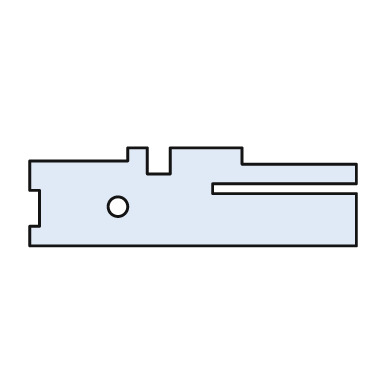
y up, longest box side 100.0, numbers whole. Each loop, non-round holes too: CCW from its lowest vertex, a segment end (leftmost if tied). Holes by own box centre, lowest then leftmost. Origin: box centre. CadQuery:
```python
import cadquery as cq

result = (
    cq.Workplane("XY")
    .moveTo(-50.0, -15.0)
    .lineTo(50.0, -15.0)
    .lineTo(50.0, 1.0)
    .lineTo(6.0, 1.0)
    .lineTo(6.0, 4.0)
    .lineTo(50.0, 4.0)
    .lineTo(50.0, 10.0)
    .lineTo(15.0, 10.0)
    .lineTo(15.0, 15.0)
    .lineTo(-7.0, 15.0)
    .lineTo(-7.0, 7.0)
    .lineTo(-14.0, 7.0)
    .lineTo(-14.0, 15.0)
    .lineTo(-20.0, 15.0)
    .lineTo(-20.0, 11.0)
    .lineTo(-50.0, 11.0)
    .lineTo(-50.0, 2.0)
    .lineTo(-47.0, 2.0)
    .lineTo(-47.0, -9.0)
    .lineTo(-50.0, -9.0)
    .close()
    .moveTo(-23.0, -3.0)
    .circle(3.0)
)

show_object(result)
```